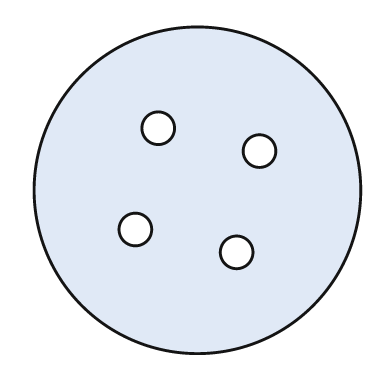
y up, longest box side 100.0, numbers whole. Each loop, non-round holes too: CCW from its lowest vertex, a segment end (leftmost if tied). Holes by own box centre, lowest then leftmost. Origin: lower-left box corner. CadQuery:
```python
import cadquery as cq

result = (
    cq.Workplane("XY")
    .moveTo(50.0, 50.0)
    .circle(50.0)
    .moveTo(62.0, 31.0)
    .circle(5.0)
    .moveTo(31.0, 38.0)
    .circle(5.0)
    .moveTo(69.0, 62.0)
    .circle(5.0)
    .moveTo(38.0, 69.0)
    .circle(5.0)
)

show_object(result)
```